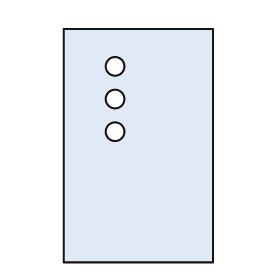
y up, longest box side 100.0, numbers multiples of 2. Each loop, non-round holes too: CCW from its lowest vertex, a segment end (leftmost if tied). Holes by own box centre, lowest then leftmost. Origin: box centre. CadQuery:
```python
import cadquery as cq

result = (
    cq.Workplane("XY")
    .moveTo(-32.0, -50.0)
    .lineTo(32.0, -50.0)
    .lineTo(32.0, 50.0)
    .lineTo(-32.0, 50.0)
    .close()
    .moveTo(-10.0, 6.0)
    .circle(4.0)
    .moveTo(-10.0, 20.0)
    .circle(4.0)
    .moveTo(-10.0, 34.0)
    .circle(4.0)
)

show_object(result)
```